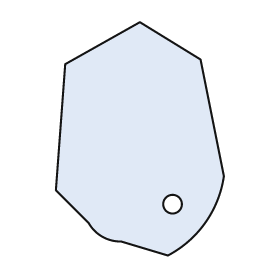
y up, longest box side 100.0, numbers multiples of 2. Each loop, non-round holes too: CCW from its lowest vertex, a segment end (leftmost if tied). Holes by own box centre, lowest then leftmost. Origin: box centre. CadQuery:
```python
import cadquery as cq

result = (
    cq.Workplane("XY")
    .moveTo(12.0, -50.0)
    .threePointArc((28.0, -36.0), (36.0, -16.0))
    .lineTo(26.0, 34.0)
    .lineTo(0.0, 50.0)
    .lineTo(-32.0, 32.0)
    .lineTo(-36.0, -22.0)
    .lineTo(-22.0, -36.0)
    .threePointArc((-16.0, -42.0), (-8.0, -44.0))
    .close()
    .moveTo(14.0, -28.0)
    .circle(4.0)
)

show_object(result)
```